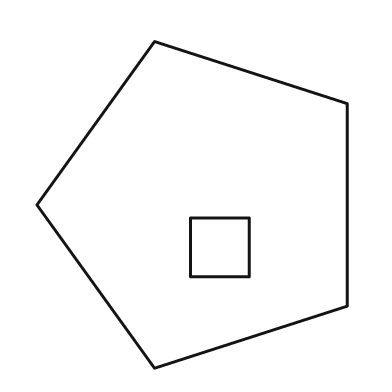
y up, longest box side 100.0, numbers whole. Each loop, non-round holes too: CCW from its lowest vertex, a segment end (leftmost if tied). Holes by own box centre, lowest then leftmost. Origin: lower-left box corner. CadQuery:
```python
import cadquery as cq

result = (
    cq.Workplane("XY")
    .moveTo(36.0, 0.0)
    .lineTo(95.0, 19.0)
    .lineTo(95.0, 81.0)
    .lineTo(36.0, 100.0)
    .lineTo(0.0, 50.0)
    .close()
    .moveTo(47.0, 28.0)
    .lineTo(65.0, 28.0)
    .lineTo(65.0, 46.0)
    .lineTo(47.0, 46.0)
    .close()
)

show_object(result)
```